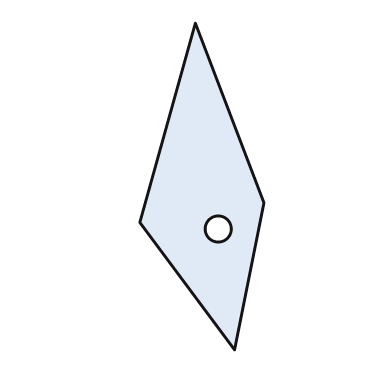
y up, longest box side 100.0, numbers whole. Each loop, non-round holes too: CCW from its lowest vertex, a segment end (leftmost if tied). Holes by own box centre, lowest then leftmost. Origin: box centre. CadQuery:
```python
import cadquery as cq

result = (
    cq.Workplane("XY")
    .moveTo(10.0, -50.0)
    .lineTo(19.0, -5.0)
    .lineTo(-2.0, 50.0)
    .lineTo(-19.0, -11.0)
    .close()
    .moveTo(5.0, -13.0)
    .circle(4.0)
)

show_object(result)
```